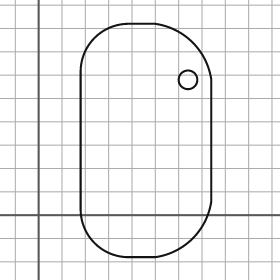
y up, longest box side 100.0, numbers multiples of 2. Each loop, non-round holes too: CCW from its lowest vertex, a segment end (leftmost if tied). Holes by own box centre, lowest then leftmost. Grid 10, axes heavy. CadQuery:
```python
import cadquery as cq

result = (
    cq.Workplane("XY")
    .moveTo(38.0, -18.0)
    .lineTo(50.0, -18.0)
    .threePointArc((66.0, -10.0), (74.0, 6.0))
    .lineTo(74.0, 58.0)
    .threePointArc((66.0, 74.0), (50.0, 82.0))
    .lineTo(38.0, 82.0)
    .threePointArc((24.0, 76.0), (18.0, 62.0))
    .lineTo(18.0, 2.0)
    .threePointArc((24.0, -12.0), (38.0, -18.0))
    .close()
    .moveTo(64.0, 58.0)
    .circle(4.0)
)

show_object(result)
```